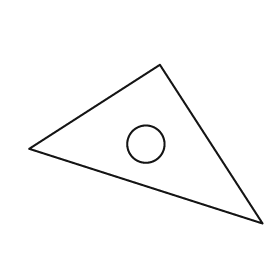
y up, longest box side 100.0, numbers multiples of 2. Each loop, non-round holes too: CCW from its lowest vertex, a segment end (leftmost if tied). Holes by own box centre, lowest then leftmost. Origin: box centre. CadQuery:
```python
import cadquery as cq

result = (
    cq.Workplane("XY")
    .moveTo(50.0, -34.0)
    .lineTo(6.0, 34.0)
    .lineTo(-50.0, -2.0)
    .close()
    .moveTo(0.0, 0.0)
    .circle(8.0)
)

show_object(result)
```